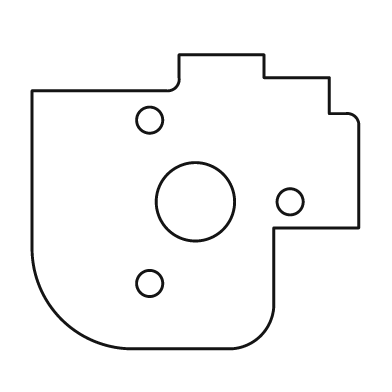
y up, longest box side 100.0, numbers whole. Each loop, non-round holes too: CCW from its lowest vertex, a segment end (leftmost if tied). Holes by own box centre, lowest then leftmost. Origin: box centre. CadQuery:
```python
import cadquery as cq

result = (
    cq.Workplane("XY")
    .moveTo(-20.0, -45.0)
    .lineTo(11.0, -45.0)
    .threePointArc((20.0, -41.0), (24.0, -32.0))
    .lineTo(24.0, -8.0)
    .lineTo(50.0, -8.0)
    .lineTo(50.0, 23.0)
    .threePointArc((49.0, 26.0), (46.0, 27.0))
    .lineTo(41.0, 27.0)
    .lineTo(41.0, 38.0)
    .lineTo(21.0, 38.0)
    .lineTo(21.0, 45.0)
    .lineTo(-5.0, 45.0)
    .lineTo(-5.0, 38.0)
    .threePointArc((-6.0, 35.0), (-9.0, 34.0))
    .lineTo(-50.0, 34.0)
    .lineTo(-50.0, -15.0)
    .threePointArc((-41.0, -36.0), (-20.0, -45.0))
    .close()
    .moveTo(-14.0, -25.0)
    .circle(4.0)
    .moveTo(0.0, 0.0)
    .circle(12.0)
    .moveTo(29.0, 0.0)
    .circle(4.0)
    .moveTo(-14.0, 25.0)
    .circle(4.0)
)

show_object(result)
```